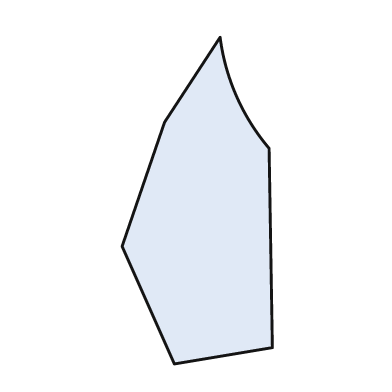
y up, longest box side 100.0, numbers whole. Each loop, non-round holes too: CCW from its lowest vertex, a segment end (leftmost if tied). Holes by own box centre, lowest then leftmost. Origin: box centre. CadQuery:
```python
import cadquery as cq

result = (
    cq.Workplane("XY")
    .moveTo(-7.0, -50.0)
    .lineTo(23.0, -45.0)
    .lineTo(22.0, 16.0)
    .threePointArc((12.0, 32.0), (7.0, 50.0))
    .lineTo(-10.0, 24.0)
    .lineTo(-23.0, -14.0)
    .close()
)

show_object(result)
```